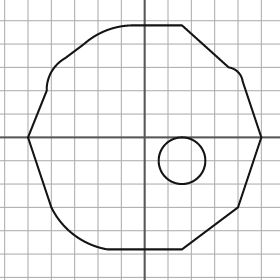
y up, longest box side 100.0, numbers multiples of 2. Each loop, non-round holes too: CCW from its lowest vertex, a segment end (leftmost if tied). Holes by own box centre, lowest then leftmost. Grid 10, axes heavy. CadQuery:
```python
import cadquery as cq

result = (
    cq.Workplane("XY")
    .moveTo(-16.0, -48.0)
    .lineTo(16.0, -48.0)
    .lineTo(40.0, -30.0)
    .lineTo(50.0, 0.0)
    .lineTo(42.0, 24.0)
    .threePointArc((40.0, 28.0), (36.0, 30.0))
    .lineTo(16.0, 48.0)
    .lineTo(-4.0, 48.0)
    .threePointArc((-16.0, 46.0), (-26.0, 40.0))
    .lineTo(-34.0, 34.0)
    .threePointArc((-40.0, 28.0), (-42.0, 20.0))
    .lineTo(-50.0, 0.0)
    .lineTo(-40.0, -30.0)
    .threePointArc((-30.0, -42.0), (-16.0, -48.0))
    .close()
    .moveTo(16.0, -10.0)
    .circle(10.0)
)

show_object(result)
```